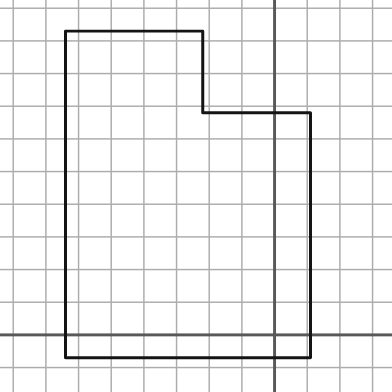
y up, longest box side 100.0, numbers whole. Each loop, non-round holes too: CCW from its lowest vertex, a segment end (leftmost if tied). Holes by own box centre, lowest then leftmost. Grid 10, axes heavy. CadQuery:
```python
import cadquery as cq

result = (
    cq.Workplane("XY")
    .moveTo(-64.0, -7.0)
    .lineTo(11.0, -7.0)
    .lineTo(11.0, 68.0)
    .lineTo(-22.0, 68.0)
    .lineTo(-22.0, 93.0)
    .lineTo(-64.0, 93.0)
    .close()
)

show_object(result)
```